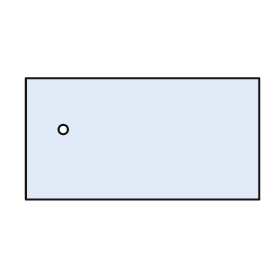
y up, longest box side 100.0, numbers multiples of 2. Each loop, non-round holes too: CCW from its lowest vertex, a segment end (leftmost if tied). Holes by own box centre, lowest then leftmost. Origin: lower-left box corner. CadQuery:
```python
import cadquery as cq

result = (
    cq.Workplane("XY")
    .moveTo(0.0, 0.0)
    .lineTo(100.0, 0.0)
    .lineTo(100.0, 52.0)
    .lineTo(0.0, 52.0)
    .close()
    .moveTo(16.0, 30.0)
    .circle(2.0)
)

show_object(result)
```